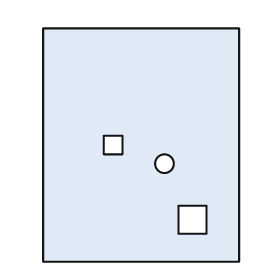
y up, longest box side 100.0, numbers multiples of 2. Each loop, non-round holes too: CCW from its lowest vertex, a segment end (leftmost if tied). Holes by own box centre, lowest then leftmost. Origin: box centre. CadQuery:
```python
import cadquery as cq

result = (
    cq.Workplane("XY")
    .moveTo(-42.0, -50.0)
    .lineTo(42.0, -50.0)
    .lineTo(42.0, 50.0)
    .lineTo(-42.0, 50.0)
    .close()
    .moveTo(16.0, -38.0)
    .lineTo(28.0, -38.0)
    .lineTo(28.0, -26.0)
    .lineTo(16.0, -26.0)
    .close()
    .moveTo(10.0, -8.0)
    .circle(4.0)
    .moveTo(-16.0, -4.0)
    .lineTo(-8.0, -4.0)
    .lineTo(-8.0, 4.0)
    .lineTo(-16.0, 4.0)
    .close()
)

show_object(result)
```